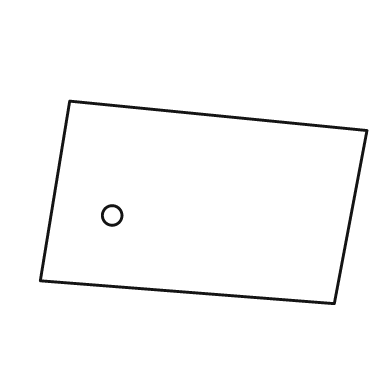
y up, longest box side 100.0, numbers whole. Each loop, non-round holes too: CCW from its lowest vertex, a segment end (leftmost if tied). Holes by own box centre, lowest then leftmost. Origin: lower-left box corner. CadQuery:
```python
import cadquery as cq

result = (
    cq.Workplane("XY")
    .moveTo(90.0, 0.0)
    .lineTo(100.0, 53.0)
    .lineTo(9.0, 62.0)
    .lineTo(0.0, 7.0)
    .close()
    .moveTo(22.0, 27.0)
    .circle(3.0)
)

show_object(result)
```